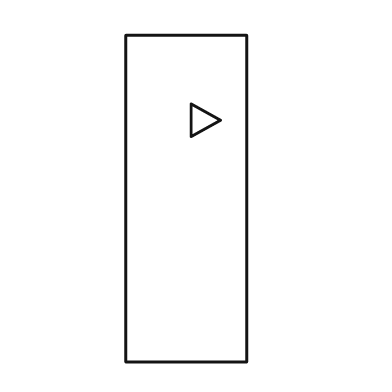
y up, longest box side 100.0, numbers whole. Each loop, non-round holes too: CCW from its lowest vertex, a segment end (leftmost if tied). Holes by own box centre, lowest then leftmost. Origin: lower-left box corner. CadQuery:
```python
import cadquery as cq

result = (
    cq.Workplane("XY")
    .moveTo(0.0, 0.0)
    .lineTo(37.0, 0.0)
    .lineTo(37.0, 100.0)
    .lineTo(0.0, 100.0)
    .close()
    .moveTo(20.0, 69.0)
    .lineTo(29.0, 74.0)
    .lineTo(20.0, 79.0)
    .close()
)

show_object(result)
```